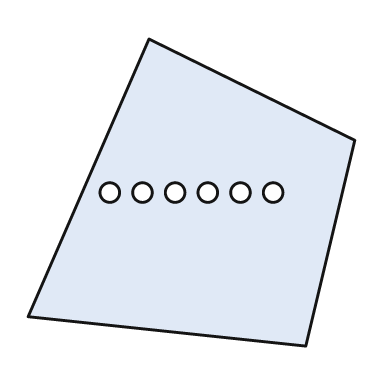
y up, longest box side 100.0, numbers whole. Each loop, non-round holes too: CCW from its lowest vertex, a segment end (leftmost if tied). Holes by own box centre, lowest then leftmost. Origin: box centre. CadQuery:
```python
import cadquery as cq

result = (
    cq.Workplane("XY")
    .moveTo(35.0, -47.0)
    .lineTo(50.0, 16.0)
    .lineTo(-13.0, 47.0)
    .lineTo(-50.0, -38.0)
    .close()
    .moveTo(-25.0, 0.0)
    .circle(3.0)
    .moveTo(-15.0, 0.0)
    .circle(3.0)
    .moveTo(-5.0, 0.0)
    .circle(3.0)
    .moveTo(5.0, 0.0)
    .circle(3.0)
    .moveTo(15.0, 0.0)
    .circle(3.0)
    .moveTo(25.0, 0.0)
    .circle(3.0)
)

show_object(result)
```